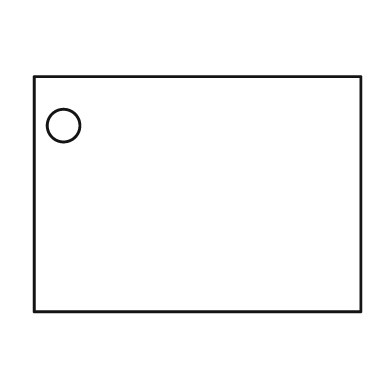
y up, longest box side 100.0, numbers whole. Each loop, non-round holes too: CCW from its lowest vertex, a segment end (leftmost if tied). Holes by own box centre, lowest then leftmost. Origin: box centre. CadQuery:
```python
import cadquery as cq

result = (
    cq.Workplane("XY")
    .moveTo(-50.0, -36.0)
    .lineTo(50.0, -36.0)
    .lineTo(50.0, 36.0)
    .lineTo(-50.0, 36.0)
    .close()
    .moveTo(-41.0, 21.0)
    .circle(5.0)
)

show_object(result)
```